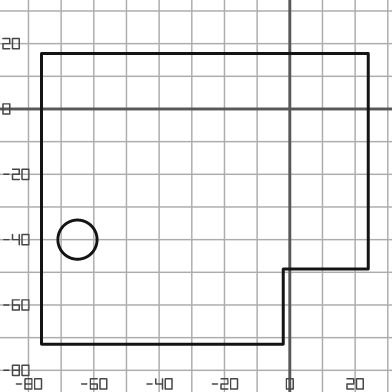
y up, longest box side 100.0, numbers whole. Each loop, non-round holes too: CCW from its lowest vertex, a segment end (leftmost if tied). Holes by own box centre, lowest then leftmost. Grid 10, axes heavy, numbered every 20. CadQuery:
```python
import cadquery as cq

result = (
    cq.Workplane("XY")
    .moveTo(-76.0, -72.0)
    .lineTo(-2.0, -72.0)
    .lineTo(-2.0, -49.0)
    .lineTo(24.0, -49.0)
    .lineTo(24.0, 17.0)
    .lineTo(-76.0, 17.0)
    .close()
    .moveTo(-65.0, -40.0)
    .circle(6.0)
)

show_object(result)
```